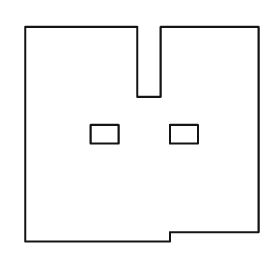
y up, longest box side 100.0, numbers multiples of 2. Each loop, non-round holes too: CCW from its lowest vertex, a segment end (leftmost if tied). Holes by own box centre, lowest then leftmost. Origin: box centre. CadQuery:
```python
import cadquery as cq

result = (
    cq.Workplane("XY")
    .moveTo(-50.0, -46.0)
    .lineTo(12.0, -46.0)
    .lineTo(12.0, -42.0)
    .lineTo(50.0, -42.0)
    .lineTo(50.0, 46.0)
    .lineTo(8.0, 46.0)
    .lineTo(8.0, 16.0)
    .lineTo(-2.0, 16.0)
    .lineTo(-2.0, 46.0)
    .lineTo(-50.0, 46.0)
    .close()
    .moveTo(-22.0, -4.0)
    .lineTo(-10.0, -4.0)
    .lineTo(-10.0, 4.0)
    .lineTo(-22.0, 4.0)
    .close()
    .moveTo(12.0, -4.0)
    .lineTo(24.0, -4.0)
    .lineTo(24.0, 4.0)
    .lineTo(12.0, 4.0)
    .close()
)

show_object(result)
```